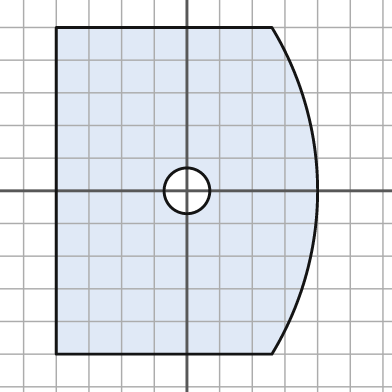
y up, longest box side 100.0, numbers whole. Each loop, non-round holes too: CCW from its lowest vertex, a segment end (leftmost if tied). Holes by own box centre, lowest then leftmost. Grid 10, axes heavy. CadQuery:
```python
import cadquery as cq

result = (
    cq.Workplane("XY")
    .moveTo(-40.0, -50.0)
    .lineTo(26.0, -50.0)
    .threePointArc((40.0, 0.0), (26.0, 50.0))
    .lineTo(-40.0, 50.0)
    .close()
    .moveTo(0.0, 0.0)
    .circle(7.0)
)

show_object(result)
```